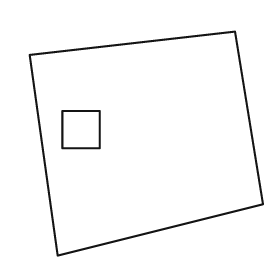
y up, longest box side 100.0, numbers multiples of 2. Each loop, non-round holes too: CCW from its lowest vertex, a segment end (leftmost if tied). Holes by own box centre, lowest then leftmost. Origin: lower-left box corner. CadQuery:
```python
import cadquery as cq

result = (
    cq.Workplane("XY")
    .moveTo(12.0, 0.0)
    .lineTo(100.0, 22.0)
    .lineTo(88.0, 96.0)
    .lineTo(0.0, 86.0)
    .close()
    .moveTo(14.0, 46.0)
    .lineTo(30.0, 46.0)
    .lineTo(30.0, 62.0)
    .lineTo(14.0, 62.0)
    .close()
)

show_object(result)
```